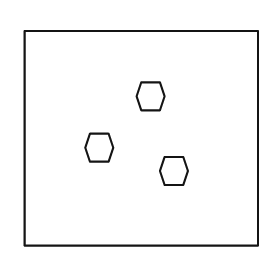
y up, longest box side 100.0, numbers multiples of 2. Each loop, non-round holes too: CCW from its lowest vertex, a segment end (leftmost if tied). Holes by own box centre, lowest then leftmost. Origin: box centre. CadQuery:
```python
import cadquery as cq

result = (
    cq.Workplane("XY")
    .moveTo(-50.0, -46.0)
    .lineTo(50.0, -46.0)
    .lineTo(50.0, 46.0)
    .lineTo(-50.0, 46.0)
    .close()
    .moveTo(10.0, -20.0)
    .lineTo(18.0, -20.0)
    .lineTo(20.0, -14.0)
    .lineTo(18.0, -8.0)
    .lineTo(10.0, -8.0)
    .lineTo(8.0, -14.0)
    .close()
    .moveTo(-22.0, -10.0)
    .lineTo(-14.0, -10.0)
    .lineTo(-12.0, -4.0)
    .lineTo(-14.0, 2.0)
    .lineTo(-22.0, 2.0)
    .lineTo(-24.0, -4.0)
    .close()
    .moveTo(0.0, 12.0)
    .lineTo(8.0, 12.0)
    .lineTo(10.0, 18.0)
    .lineTo(8.0, 24.0)
    .lineTo(0.0, 24.0)
    .lineTo(-2.0, 18.0)
    .close()
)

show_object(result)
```